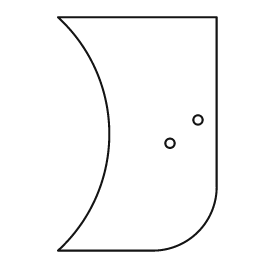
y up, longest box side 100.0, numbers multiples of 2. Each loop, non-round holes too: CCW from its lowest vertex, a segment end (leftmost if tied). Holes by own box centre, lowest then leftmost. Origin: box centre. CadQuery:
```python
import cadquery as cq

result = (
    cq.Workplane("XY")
    .moveTo(-34.0, -50.0)
    .lineTo(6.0, -50.0)
    .threePointArc((26.0, -42.0), (34.0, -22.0))
    .lineTo(34.0, 50.0)
    .lineTo(-34.0, 50.0)
    .threePointArc((-12.0, 0.0), (-34.0, -50.0))
    .close()
    .moveTo(14.0, -4.0)
    .circle(2.0)
    .moveTo(26.0, 6.0)
    .circle(2.0)
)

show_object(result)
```